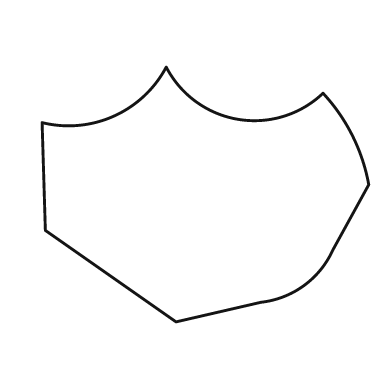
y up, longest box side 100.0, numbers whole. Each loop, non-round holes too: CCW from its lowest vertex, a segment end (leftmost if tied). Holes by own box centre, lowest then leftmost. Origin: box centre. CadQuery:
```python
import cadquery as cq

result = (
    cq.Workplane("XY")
    .moveTo(-9.0, -39.0)
    .lineTo(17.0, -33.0)
    .threePointArc((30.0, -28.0), (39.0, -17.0))
    .lineTo(50.0, 3.0)
    .threePointArc((45.0, 18.0), (36.0, 31.0))
    .threePointArc((10.0, 23.0), (-12.0, 39.0))
    .threePointArc((-28.0, 24.0), (-50.0, 22.0))
    .lineTo(-49.0, -11.0)
    .close()
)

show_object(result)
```